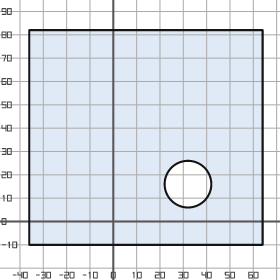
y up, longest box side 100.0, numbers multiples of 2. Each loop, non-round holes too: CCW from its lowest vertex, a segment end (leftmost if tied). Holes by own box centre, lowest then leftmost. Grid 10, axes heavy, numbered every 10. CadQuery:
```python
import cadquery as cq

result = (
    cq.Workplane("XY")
    .moveTo(-36.0, -10.0)
    .lineTo(64.0, -10.0)
    .lineTo(64.0, 82.0)
    .lineTo(-36.0, 82.0)
    .close()
    .moveTo(32.0, 16.0)
    .circle(10.0)
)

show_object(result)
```